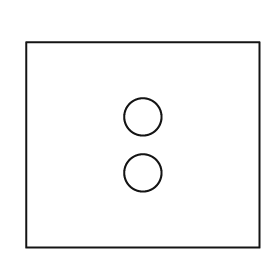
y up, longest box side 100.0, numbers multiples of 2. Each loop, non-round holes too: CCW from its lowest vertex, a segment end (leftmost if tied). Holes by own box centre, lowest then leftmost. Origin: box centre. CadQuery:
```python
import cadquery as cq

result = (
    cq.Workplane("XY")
    .moveTo(-50.0, -44.0)
    .lineTo(50.0, -44.0)
    .lineTo(50.0, 44.0)
    .lineTo(-50.0, 44.0)
    .close()
    .moveTo(0.0, -12.0)
    .circle(8.0)
    .moveTo(0.0, 12.0)
    .circle(8.0)
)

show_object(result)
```